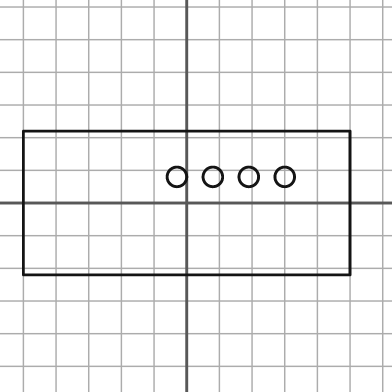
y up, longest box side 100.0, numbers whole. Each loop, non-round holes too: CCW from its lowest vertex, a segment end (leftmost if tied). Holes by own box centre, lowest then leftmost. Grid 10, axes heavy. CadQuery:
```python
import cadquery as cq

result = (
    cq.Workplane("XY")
    .moveTo(-50.0, -22.0)
    .lineTo(50.0, -22.0)
    .lineTo(50.0, 22.0)
    .lineTo(-50.0, 22.0)
    .close()
    .moveTo(-3.0, 8.0)
    .circle(3.0)
    .moveTo(8.0, 8.0)
    .circle(3.0)
    .moveTo(19.0, 8.0)
    .circle(3.0)
    .moveTo(30.0, 8.0)
    .circle(3.0)
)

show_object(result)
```